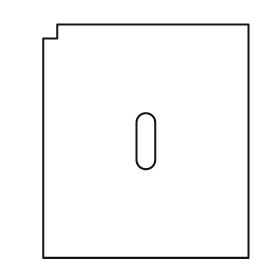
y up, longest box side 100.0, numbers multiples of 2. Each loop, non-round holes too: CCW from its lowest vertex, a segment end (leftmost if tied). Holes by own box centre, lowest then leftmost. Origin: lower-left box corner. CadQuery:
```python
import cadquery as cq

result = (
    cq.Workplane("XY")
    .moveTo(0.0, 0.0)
    .lineTo(88.0, 0.0)
    .lineTo(88.0, 100.0)
    .lineTo(6.0, 100.0)
    .lineTo(6.0, 94.0)
    .lineTo(0.0, 94.0)
    .close()
    .moveTo(40.0, 42.0)
    .threePointArc((44.0, 38.0), (48.0, 42.0))
    .lineTo(48.0, 58.0)
    .threePointArc((44.0, 62.0), (40.0, 58.0))
    .close()
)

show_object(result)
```